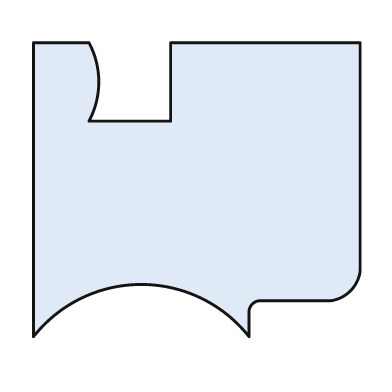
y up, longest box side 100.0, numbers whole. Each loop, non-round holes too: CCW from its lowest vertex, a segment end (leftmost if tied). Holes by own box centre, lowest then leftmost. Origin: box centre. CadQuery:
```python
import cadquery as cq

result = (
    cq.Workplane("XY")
    .moveTo(-50.0, -45.0)
    .threePointArc((-17.0, -29.0), (16.0, -45.0))
    .lineTo(16.0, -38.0)
    .threePointArc((17.0, -35.0), (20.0, -34.0))
    .lineTo(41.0, -34.0)
    .threePointArc((47.0, -31.0), (50.0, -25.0))
    .lineTo(50.0, 45.0)
    .lineTo(-8.0, 45.0)
    .lineTo(-8.0, 21.0)
    .lineTo(-33.0, 21.0)
    .threePointArc((-30.0, 33.0), (-33.0, 45.0))
    .lineTo(-50.0, 45.0)
    .close()
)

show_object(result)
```